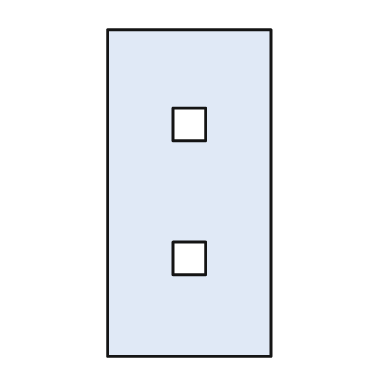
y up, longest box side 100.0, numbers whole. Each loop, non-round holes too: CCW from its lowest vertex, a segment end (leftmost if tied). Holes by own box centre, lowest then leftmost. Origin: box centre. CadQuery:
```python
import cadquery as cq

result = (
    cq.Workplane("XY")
    .moveTo(-25.0, -50.0)
    .lineTo(25.0, -50.0)
    .lineTo(25.0, 50.0)
    .lineTo(-25.0, 50.0)
    .close()
    .moveTo(-5.0, -25.0)
    .lineTo(5.0, -25.0)
    .lineTo(5.0, -15.0)
    .lineTo(-5.0, -15.0)
    .close()
    .moveTo(-5.0, 16.0)
    .lineTo(5.0, 16.0)
    .lineTo(5.0, 26.0)
    .lineTo(-5.0, 26.0)
    .close()
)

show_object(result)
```